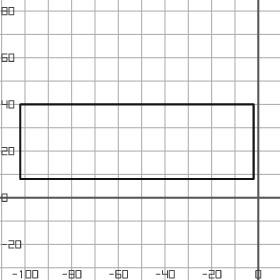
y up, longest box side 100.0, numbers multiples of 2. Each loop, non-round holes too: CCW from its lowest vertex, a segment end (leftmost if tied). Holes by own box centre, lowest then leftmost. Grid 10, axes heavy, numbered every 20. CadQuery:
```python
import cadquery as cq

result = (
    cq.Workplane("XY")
    .moveTo(-102.0, 8.0)
    .lineTo(-2.0, 8.0)
    .lineTo(-2.0, 40.0)
    .lineTo(-102.0, 40.0)
    .close()
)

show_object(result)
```